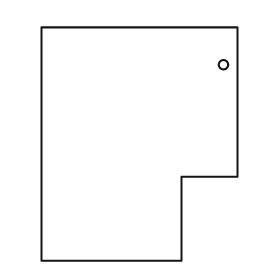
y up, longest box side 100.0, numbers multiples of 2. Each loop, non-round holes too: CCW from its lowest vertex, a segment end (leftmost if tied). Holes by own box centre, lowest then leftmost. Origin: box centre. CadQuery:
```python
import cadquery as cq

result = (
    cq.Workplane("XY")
    .moveTo(-42.0, -50.0)
    .lineTo(18.0, -50.0)
    .lineTo(18.0, -14.0)
    .lineTo(42.0, -14.0)
    .lineTo(42.0, 50.0)
    .lineTo(-42.0, 50.0)
    .close()
    .moveTo(36.0, 34.0)
    .circle(2.0)
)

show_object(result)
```